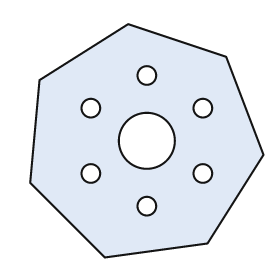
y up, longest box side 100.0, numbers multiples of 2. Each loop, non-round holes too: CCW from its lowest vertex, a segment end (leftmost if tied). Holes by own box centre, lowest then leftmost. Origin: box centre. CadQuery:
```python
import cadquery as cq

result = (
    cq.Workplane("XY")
    .moveTo(-18.0, -50.0)
    .lineTo(26.0, -44.0)
    .lineTo(50.0, -6.0)
    .lineTo(34.0, 36.0)
    .lineTo(-8.0, 50.0)
    .lineTo(-46.0, 26.0)
    .lineTo(-50.0, -18.0)
    .close()
    .moveTo(0.0, -28.0)
    .circle(4.0)
    .moveTo(-24.0, -14.0)
    .circle(4.0)
    .moveTo(24.0, -14.0)
    .circle(4.0)
    .moveTo(0.0, 0.0)
    .circle(12.0)
    .moveTo(-24.0, 14.0)
    .circle(4.0)
    .moveTo(24.0, 14.0)
    .circle(4.0)
    .moveTo(0.0, 28.0)
    .circle(4.0)
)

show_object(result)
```